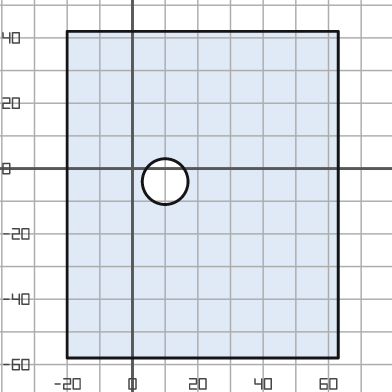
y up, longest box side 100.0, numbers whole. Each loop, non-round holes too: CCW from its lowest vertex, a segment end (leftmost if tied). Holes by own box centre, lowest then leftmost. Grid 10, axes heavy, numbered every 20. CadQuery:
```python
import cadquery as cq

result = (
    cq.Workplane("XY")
    .moveTo(-20.0, -58.0)
    .lineTo(63.0, -58.0)
    .lineTo(63.0, 42.0)
    .lineTo(-20.0, 42.0)
    .close()
    .moveTo(10.0, -4.0)
    .circle(7.0)
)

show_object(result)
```